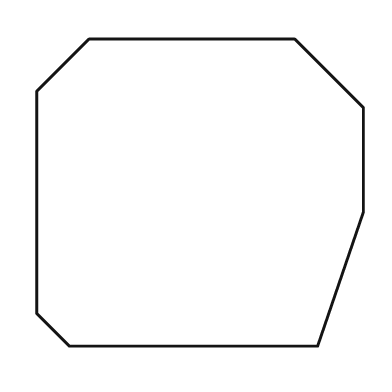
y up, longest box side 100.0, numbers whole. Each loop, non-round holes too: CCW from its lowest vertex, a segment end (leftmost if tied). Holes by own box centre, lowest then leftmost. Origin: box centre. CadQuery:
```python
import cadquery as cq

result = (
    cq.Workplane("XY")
    .moveTo(-40.0, -47.0)
    .lineTo(36.0, -47.0)
    .lineTo(50.0, -6.0)
    .lineTo(50.0, 26.0)
    .lineTo(29.0, 47.0)
    .lineTo(-34.0, 47.0)
    .lineTo(-50.0, 31.0)
    .lineTo(-50.0, -37.0)
    .close()
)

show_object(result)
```